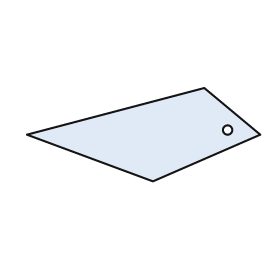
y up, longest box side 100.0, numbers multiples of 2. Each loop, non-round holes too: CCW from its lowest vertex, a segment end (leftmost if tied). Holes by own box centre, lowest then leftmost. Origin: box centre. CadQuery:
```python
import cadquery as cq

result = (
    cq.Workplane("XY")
    .moveTo(4.0, -20.0)
    .lineTo(50.0, 0.0)
    .lineTo(26.0, 20.0)
    .lineTo(-50.0, 0.0)
    .close()
    .moveTo(36.0, 2.0)
    .circle(2.0)
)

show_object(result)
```